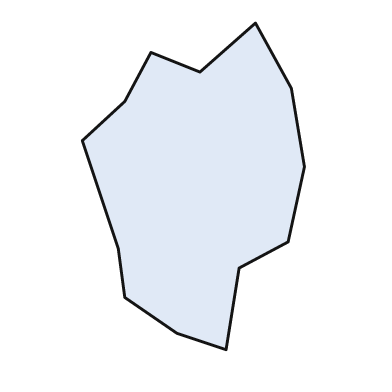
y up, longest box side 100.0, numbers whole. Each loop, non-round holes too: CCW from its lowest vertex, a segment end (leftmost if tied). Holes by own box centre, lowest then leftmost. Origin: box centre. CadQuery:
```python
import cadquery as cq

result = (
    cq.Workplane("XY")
    .moveTo(10.0, -50.0)
    .lineTo(14.0, -25.0)
    .lineTo(29.0, -17.0)
    .lineTo(34.0, 6.0)
    .lineTo(30.0, 30.0)
    .lineTo(19.0, 50.0)
    .lineTo(2.0, 35.0)
    .lineTo(-13.0, 41.0)
    .lineTo(-21.0, 26.0)
    .lineTo(-34.0, 14.0)
    .lineTo(-23.0, -19.0)
    .lineTo(-21.0, -34.0)
    .lineTo(-5.0, -45.0)
    .close()
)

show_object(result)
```